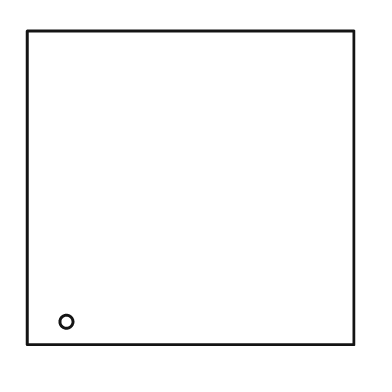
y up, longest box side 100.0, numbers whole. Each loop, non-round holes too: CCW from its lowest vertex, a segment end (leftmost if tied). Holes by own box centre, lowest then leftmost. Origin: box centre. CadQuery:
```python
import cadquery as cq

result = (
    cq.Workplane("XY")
    .moveTo(-50.0, -48.0)
    .lineTo(50.0, -48.0)
    .lineTo(50.0, 48.0)
    .lineTo(-50.0, 48.0)
    .close()
    .moveTo(-38.0, -41.0)
    .circle(2.0)
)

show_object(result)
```